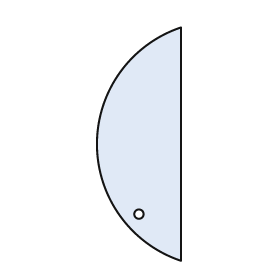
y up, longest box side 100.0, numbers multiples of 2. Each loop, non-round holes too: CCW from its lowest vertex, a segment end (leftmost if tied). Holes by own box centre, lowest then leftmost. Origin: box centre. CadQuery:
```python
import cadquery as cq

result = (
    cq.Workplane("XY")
    .moveTo(18.0, -50.0)
    .lineTo(18.0, 50.0)
    .threePointArc((-18.0, 0.0), (18.0, -50.0))
    .close()
    .moveTo(0.0, -30.0)
    .circle(2.0)
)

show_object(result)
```